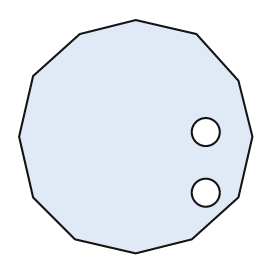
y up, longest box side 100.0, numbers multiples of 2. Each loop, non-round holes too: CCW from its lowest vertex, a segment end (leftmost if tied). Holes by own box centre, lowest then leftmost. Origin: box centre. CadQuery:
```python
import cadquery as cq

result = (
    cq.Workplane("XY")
    .moveTo(0.0, -50.0)
    .lineTo(24.0, -44.0)
    .lineTo(44.0, -26.0)
    .lineTo(50.0, 0.0)
    .lineTo(44.0, 24.0)
    .lineTo(26.0, 44.0)
    .lineTo(0.0, 50.0)
    .lineTo(-24.0, 44.0)
    .lineTo(-44.0, 26.0)
    .lineTo(-50.0, 0.0)
    .lineTo(-44.0, -26.0)
    .lineTo(-26.0, -44.0)
    .close()
    .moveTo(30.0, -24.0)
    .circle(6.0)
    .moveTo(30.0, 2.0)
    .circle(6.0)
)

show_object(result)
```